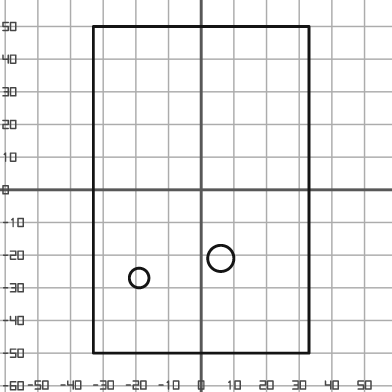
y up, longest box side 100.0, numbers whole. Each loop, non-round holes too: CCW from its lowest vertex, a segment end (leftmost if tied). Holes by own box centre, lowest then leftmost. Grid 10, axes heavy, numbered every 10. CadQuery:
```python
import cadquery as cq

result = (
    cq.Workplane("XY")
    .moveTo(-33.0, -50.0)
    .lineTo(33.0, -50.0)
    .lineTo(33.0, 50.0)
    .lineTo(-33.0, 50.0)
    .close()
    .moveTo(-19.0, -27.0)
    .circle(3.0)
    .moveTo(6.0, -21.0)
    .circle(4.0)
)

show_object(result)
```